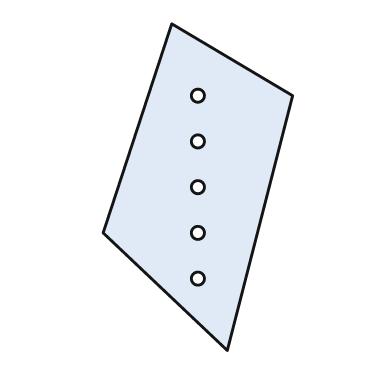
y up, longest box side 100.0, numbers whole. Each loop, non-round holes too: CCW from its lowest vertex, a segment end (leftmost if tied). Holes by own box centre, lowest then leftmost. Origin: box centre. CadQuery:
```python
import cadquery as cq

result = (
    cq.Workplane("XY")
    .moveTo(9.0, -50.0)
    .lineTo(29.0, 28.0)
    .lineTo(-8.0, 50.0)
    .lineTo(-29.0, -14.0)
    .close()
    .moveTo(0.0, -28.0)
    .circle(2.0)
    .moveTo(0.0, -14.0)
    .circle(2.0)
    .moveTo(0.0, 0.0)
    .circle(2.0)
    .moveTo(0.0, 14.0)
    .circle(2.0)
    .moveTo(0.0, 28.0)
    .circle(2.0)
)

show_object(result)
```